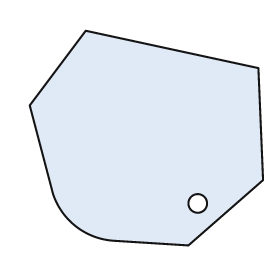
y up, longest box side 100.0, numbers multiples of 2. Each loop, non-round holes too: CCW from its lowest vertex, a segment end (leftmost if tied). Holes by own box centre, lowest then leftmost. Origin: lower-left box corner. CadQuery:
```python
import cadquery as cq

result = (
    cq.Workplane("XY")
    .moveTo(68.0, 0.0)
    .lineTo(100.0, 28.0)
    .lineTo(98.0, 76.0)
    .lineTo(24.0, 92.0)
    .lineTo(0.0, 60.0)
    .lineTo(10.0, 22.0)
    .threePointArc((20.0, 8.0), (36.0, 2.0))
    .close()
    .moveTo(72.0, 18.0)
    .circle(4.0)
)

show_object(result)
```